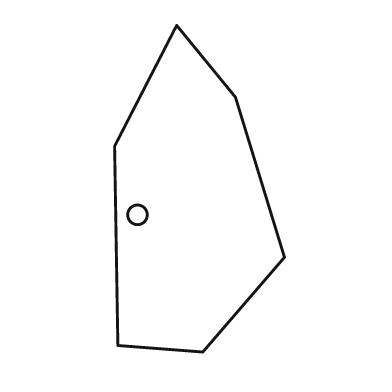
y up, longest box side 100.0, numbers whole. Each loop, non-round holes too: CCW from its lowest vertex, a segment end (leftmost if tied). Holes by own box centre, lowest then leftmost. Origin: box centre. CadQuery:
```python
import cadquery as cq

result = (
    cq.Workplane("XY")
    .moveTo(1.0, -50.0)
    .lineTo(26.0, -21.0)
    .lineTo(11.0, 28.0)
    .lineTo(-7.0, 50.0)
    .lineTo(-26.0, 13.0)
    .lineTo(-25.0, -48.0)
    .close()
    .moveTo(-19.0, -8.0)
    .circle(3.0)
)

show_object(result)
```